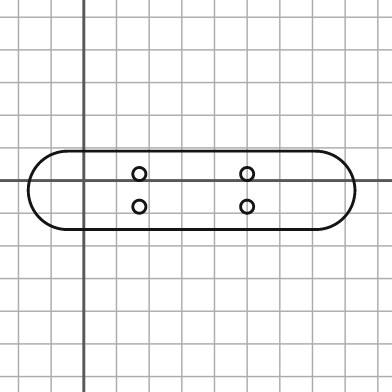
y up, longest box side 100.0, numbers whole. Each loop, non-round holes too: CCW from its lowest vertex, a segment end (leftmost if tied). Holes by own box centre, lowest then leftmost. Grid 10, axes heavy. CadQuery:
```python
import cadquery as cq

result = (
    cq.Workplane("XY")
    .moveTo(-5.0, -15.0)
    .lineTo(71.0, -15.0)
    .threePointArc((83.0, -3.0), (71.0, 9.0))
    .lineTo(-5.0, 9.0)
    .threePointArc((-17.0, -3.0), (-5.0, -15.0))
    .close()
    .moveTo(17.0, -8.0)
    .circle(2.0)
    .moveTo(50.0, -8.0)
    .circle(2.0)
    .moveTo(17.0, 2.0)
    .circle(2.0)
    .moveTo(50.0, 2.0)
    .circle(2.0)
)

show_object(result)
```